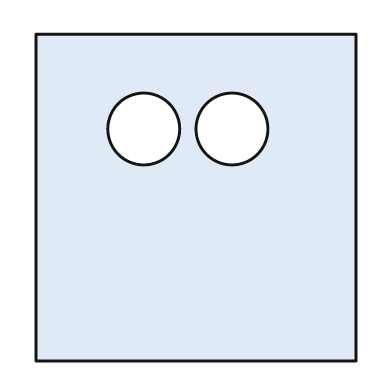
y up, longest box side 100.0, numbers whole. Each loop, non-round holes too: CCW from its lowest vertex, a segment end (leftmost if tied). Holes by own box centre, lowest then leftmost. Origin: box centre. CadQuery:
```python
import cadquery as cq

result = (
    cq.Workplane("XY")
    .moveTo(-49.0, -50.0)
    .lineTo(49.0, -50.0)
    .lineTo(49.0, 50.0)
    .lineTo(-49.0, 50.0)
    .close()
    .moveTo(-16.0, 21.0)
    .circle(11.0)
    .moveTo(11.0, 21.0)
    .circle(11.0)
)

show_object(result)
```